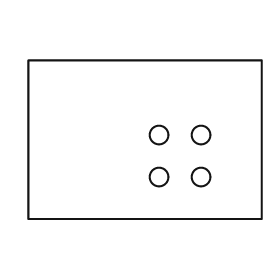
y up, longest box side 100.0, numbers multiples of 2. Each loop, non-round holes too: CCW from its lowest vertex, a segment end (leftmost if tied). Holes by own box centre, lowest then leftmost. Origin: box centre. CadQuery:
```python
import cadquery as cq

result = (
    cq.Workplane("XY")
    .moveTo(-50.0, -34.0)
    .lineTo(50.0, -34.0)
    .lineTo(50.0, 34.0)
    .lineTo(-50.0, 34.0)
    .close()
    .moveTo(6.0, -16.0)
    .circle(4.0)
    .moveTo(24.0, -16.0)
    .circle(4.0)
    .moveTo(6.0, 2.0)
    .circle(4.0)
    .moveTo(24.0, 2.0)
    .circle(4.0)
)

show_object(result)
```